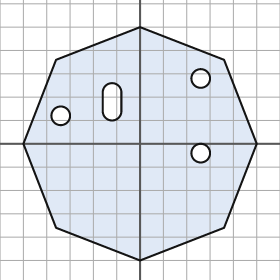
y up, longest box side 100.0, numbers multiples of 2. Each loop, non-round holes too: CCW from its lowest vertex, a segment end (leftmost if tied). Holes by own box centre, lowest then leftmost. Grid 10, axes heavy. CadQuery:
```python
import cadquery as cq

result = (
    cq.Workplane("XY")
    .moveTo(0.0, -50.0)
    .lineTo(36.0, -36.0)
    .lineTo(50.0, 0.0)
    .lineTo(36.0, 36.0)
    .lineTo(0.0, 50.0)
    .lineTo(-36.0, 36.0)
    .lineTo(-50.0, 0.0)
    .lineTo(-36.0, -36.0)
    .close()
    .moveTo(26.0, -4.0)
    .circle(4.0)
    .moveTo(-34.0, 12.0)
    .circle(4.0)
    .moveTo(-16.0, 14.0)
    .threePointArc((-12.0, 10.0), (-8.0, 14.0))
    .lineTo(-8.0, 22.0)
    .threePointArc((-12.0, 26.0), (-16.0, 22.0))
    .close()
    .moveTo(26.0, 28.0)
    .circle(4.0)
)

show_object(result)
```